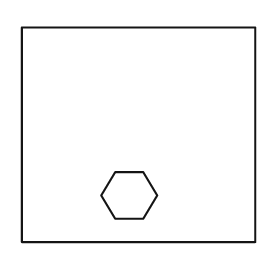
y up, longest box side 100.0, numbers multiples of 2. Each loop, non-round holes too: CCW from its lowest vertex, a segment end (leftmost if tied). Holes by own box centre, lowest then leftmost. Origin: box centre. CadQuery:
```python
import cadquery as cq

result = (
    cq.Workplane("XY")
    .moveTo(-50.0, -46.0)
    .lineTo(50.0, -46.0)
    .lineTo(50.0, 46.0)
    .lineTo(-50.0, 46.0)
    .close()
    .moveTo(-10.0, -36.0)
    .lineTo(2.0, -36.0)
    .lineTo(8.0, -26.0)
    .lineTo(2.0, -16.0)
    .lineTo(-10.0, -16.0)
    .lineTo(-16.0, -26.0)
    .close()
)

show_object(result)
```